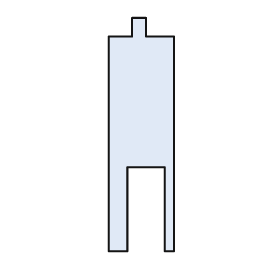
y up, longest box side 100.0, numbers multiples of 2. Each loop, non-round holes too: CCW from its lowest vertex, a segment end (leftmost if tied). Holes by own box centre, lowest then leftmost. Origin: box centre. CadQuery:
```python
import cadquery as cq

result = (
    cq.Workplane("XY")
    .moveTo(-14.0, -50.0)
    .lineTo(-6.0, -50.0)
    .lineTo(-6.0, -14.0)
    .lineTo(10.0, -14.0)
    .lineTo(10.0, -50.0)
    .lineTo(14.0, -50.0)
    .lineTo(14.0, 42.0)
    .lineTo(2.0, 42.0)
    .lineTo(2.0, 50.0)
    .lineTo(-4.0, 50.0)
    .lineTo(-4.0, 42.0)
    .lineTo(-14.0, 42.0)
    .close()
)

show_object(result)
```